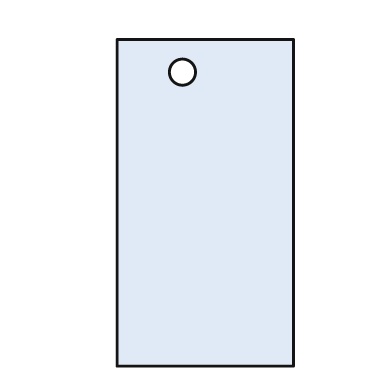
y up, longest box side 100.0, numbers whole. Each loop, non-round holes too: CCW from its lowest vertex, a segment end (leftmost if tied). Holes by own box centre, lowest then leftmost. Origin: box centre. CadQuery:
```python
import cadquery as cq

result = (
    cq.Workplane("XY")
    .moveTo(-27.0, -50.0)
    .lineTo(27.0, -50.0)
    .lineTo(27.0, 50.0)
    .lineTo(-27.0, 50.0)
    .close()
    .moveTo(-7.0, 40.0)
    .circle(4.0)
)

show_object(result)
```